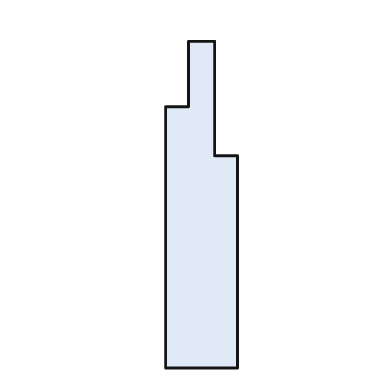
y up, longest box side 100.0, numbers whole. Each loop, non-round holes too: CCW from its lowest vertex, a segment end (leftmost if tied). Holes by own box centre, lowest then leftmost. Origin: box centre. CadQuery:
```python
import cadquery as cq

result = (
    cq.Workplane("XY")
    .moveTo(-11.0, -50.0)
    .lineTo(11.0, -50.0)
    .lineTo(11.0, 15.0)
    .lineTo(4.0, 15.0)
    .lineTo(4.0, 50.0)
    .lineTo(-4.0, 50.0)
    .lineTo(-4.0, 30.0)
    .lineTo(-11.0, 30.0)
    .close()
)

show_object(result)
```